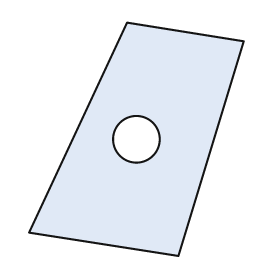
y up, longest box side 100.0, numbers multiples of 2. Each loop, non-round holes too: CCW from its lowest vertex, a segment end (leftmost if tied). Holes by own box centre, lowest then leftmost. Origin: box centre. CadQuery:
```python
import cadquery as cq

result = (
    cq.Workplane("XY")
    .moveTo(18.0, -50.0)
    .lineTo(46.0, 42.0)
    .lineTo(-4.0, 50.0)
    .lineTo(-46.0, -40.0)
    .close()
    .moveTo(0.0, 0.0)
    .circle(10.0)
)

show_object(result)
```